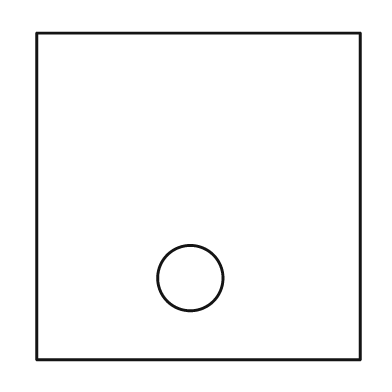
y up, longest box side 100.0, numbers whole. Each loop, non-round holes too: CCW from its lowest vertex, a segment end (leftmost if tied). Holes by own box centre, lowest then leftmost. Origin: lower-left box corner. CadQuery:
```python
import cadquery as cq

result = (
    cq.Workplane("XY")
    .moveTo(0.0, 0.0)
    .lineTo(99.0, 0.0)
    .lineTo(99.0, 100.0)
    .lineTo(0.0, 100.0)
    .close()
    .moveTo(47.0, 25.0)
    .circle(10.0)
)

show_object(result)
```